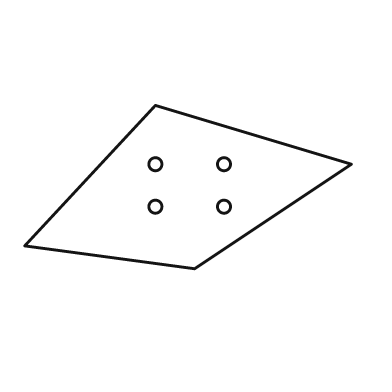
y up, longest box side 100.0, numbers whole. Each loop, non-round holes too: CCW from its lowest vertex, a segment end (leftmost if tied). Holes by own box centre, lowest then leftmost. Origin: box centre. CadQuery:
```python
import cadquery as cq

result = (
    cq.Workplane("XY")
    .moveTo(2.0, -25.0)
    .lineTo(50.0, 7.0)
    .lineTo(-10.0, 25.0)
    .lineTo(-50.0, -18.0)
    .close()
    .moveTo(-10.0, -6.0)
    .circle(2.0)
    .moveTo(11.0, -6.0)
    .circle(2.0)
    .moveTo(-10.0, 7.0)
    .circle(2.0)
    .moveTo(11.0, 7.0)
    .circle(2.0)
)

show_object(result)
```